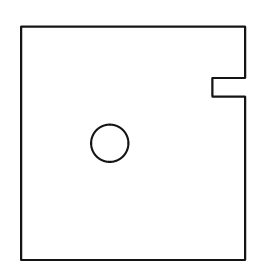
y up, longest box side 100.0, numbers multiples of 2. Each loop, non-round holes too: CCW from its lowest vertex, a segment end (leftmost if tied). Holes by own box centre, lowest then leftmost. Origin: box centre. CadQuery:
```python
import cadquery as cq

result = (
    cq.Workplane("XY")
    .moveTo(-48.0, -50.0)
    .lineTo(48.0, -50.0)
    .lineTo(48.0, 20.0)
    .lineTo(34.0, 20.0)
    .lineTo(34.0, 28.0)
    .lineTo(48.0, 28.0)
    .lineTo(48.0, 50.0)
    .lineTo(-48.0, 50.0)
    .close()
    .moveTo(-10.0, 0.0)
    .circle(8.0)
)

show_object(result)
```